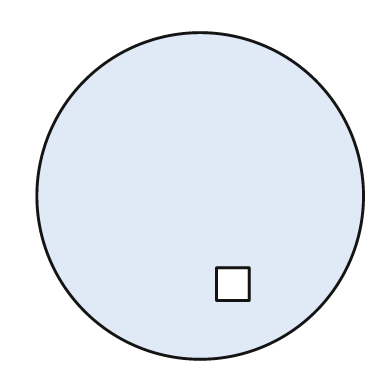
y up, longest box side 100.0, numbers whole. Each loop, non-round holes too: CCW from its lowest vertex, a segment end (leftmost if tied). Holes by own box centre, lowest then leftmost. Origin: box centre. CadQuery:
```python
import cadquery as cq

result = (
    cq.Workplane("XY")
    .moveTo(0.0, 0.0)
    .circle(50.0)
    .moveTo(5.0, -32.0)
    .lineTo(15.0, -32.0)
    .lineTo(15.0, -22.0)
    .lineTo(5.0, -22.0)
    .close()
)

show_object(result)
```